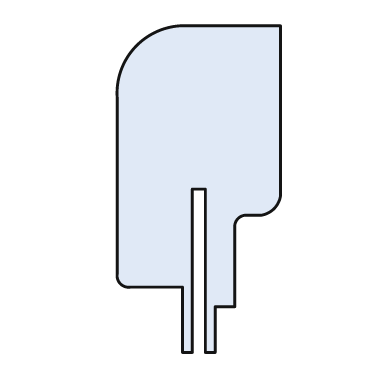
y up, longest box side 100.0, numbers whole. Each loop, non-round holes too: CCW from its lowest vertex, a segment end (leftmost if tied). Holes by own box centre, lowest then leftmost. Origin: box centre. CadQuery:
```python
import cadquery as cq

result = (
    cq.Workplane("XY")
    .moveTo(-5.0, -50.0)
    .lineTo(-2.0, -50.0)
    .lineTo(-2.0, 0.0)
    .lineTo(2.0, 0.0)
    .lineTo(2.0, -50.0)
    .lineTo(5.0, -50.0)
    .lineTo(5.0, -36.0)
    .lineTo(11.0, -36.0)
    .lineTo(11.0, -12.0)
    .threePointArc((12.0, -9.0), (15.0, -8.0))
    .lineTo(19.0, -8.0)
    .threePointArc((23.0, -6.0), (25.0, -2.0))
    .lineTo(25.0, 50.0)
    .lineTo(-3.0, 50.0)
    .threePointArc((-19.0, 44.0), (-25.0, 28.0))
    .lineTo(-25.0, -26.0)
    .threePointArc((-24.0, -29.0), (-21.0, -30.0))
    .lineTo(-5.0, -30.0)
    .close()
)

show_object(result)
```